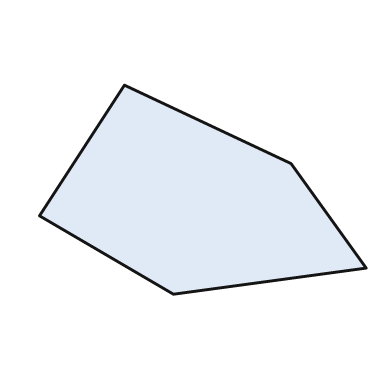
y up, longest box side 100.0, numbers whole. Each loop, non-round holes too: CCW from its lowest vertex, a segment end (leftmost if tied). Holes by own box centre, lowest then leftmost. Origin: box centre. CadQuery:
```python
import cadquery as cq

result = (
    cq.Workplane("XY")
    .moveTo(-9.0, -32.0)
    .lineTo(50.0, -24.0)
    .lineTo(27.0, 8.0)
    .lineTo(-24.0, 32.0)
    .lineTo(-50.0, -8.0)
    .close()
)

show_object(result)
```